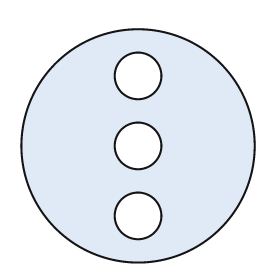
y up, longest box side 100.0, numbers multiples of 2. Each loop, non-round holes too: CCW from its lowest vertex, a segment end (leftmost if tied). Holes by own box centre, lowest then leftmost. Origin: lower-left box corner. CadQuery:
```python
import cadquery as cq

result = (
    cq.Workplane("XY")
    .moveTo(50.0, 50.0)
    .circle(50.0)
    .moveTo(50.0, 20.0)
    .circle(10.0)
    .moveTo(50.0, 50.0)
    .circle(10.0)
    .moveTo(50.0, 80.0)
    .circle(10.0)
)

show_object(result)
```